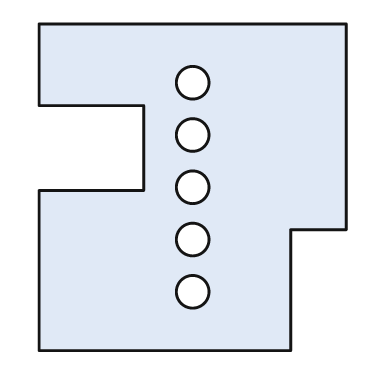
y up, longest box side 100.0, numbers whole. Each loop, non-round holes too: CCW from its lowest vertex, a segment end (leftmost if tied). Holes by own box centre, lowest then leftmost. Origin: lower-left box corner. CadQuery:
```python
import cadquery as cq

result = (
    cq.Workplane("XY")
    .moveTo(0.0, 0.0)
    .lineTo(77.0, 0.0)
    .lineTo(77.0, 37.0)
    .lineTo(94.0, 37.0)
    .lineTo(94.0, 100.0)
    .lineTo(0.0, 100.0)
    .lineTo(0.0, 75.0)
    .lineTo(32.0, 75.0)
    .lineTo(32.0, 49.0)
    .lineTo(0.0, 49.0)
    .close()
    .moveTo(47.0, 18.0)
    .circle(5.0)
    .moveTo(47.0, 34.0)
    .circle(5.0)
    .moveTo(47.0, 50.0)
    .circle(5.0)
    .moveTo(47.0, 66.0)
    .circle(5.0)
    .moveTo(47.0, 82.0)
    .circle(5.0)
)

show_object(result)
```